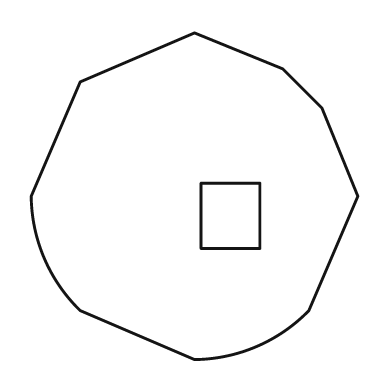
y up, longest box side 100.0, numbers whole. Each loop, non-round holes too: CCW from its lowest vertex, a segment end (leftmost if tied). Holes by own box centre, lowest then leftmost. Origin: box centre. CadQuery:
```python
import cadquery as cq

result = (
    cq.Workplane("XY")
    .moveTo(0.0, -50.0)
    .threePointArc((19.0, -46.0), (35.0, -35.0))
    .lineTo(50.0, 0.0)
    .lineTo(39.0, 27.0)
    .lineTo(27.0, 39.0)
    .lineTo(0.0, 50.0)
    .lineTo(-35.0, 35.0)
    .lineTo(-50.0, 0.0)
    .threePointArc((-46.0, -19.0), (-35.0, -35.0))
    .close()
    .moveTo(2.0, -16.0)
    .lineTo(20.0, -16.0)
    .lineTo(20.0, 4.0)
    .lineTo(2.0, 4.0)
    .close()
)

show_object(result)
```